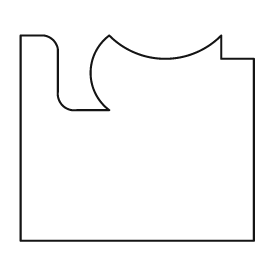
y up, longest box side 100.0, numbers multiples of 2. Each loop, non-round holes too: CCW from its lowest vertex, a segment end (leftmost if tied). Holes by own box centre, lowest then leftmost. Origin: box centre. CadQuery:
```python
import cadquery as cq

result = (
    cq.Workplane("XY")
    .moveTo(-50.0, -44.0)
    .lineTo(50.0, -44.0)
    .lineTo(50.0, 34.0)
    .lineTo(36.0, 34.0)
    .lineTo(36.0, 44.0)
    .threePointArc((12.0, 34.0), (-12.0, 44.0))
    .threePointArc((-20.0, 28.0), (-12.0, 12.0))
    .lineTo(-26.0, 12.0)
    .threePointArc((-32.0, 14.0), (-34.0, 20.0))
    .lineTo(-34.0, 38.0)
    .threePointArc((-36.0, 42.0), (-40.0, 44.0))
    .lineTo(-50.0, 44.0)
    .close()
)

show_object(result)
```